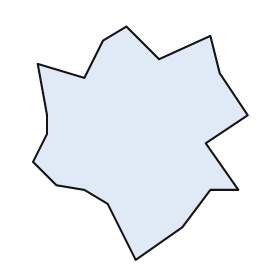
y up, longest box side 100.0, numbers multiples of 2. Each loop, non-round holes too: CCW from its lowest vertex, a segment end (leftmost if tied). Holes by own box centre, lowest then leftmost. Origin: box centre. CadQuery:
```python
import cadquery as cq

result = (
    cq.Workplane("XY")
    .moveTo(-2.0, -50.0)
    .lineTo(18.0, -36.0)
    .lineTo(30.0, -20.0)
    .lineTo(42.0, -20.0)
    .lineTo(28.0, 0.0)
    .lineTo(46.0, 12.0)
    .lineTo(34.0, 30.0)
    .lineTo(30.0, 46.0)
    .lineTo(8.0, 36.0)
    .lineTo(-6.0, 50.0)
    .lineTo(-16.0, 44.0)
    .lineTo(-24.0, 28.0)
    .lineTo(-44.0, 34.0)
    .lineTo(-40.0, 12.0)
    .lineTo(-40.0, 4.0)
    .lineTo(-46.0, -8.0)
    .lineTo(-36.0, -18.0)
    .lineTo(-24.0, -20.0)
    .lineTo(-14.0, -26.0)
    .close()
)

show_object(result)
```